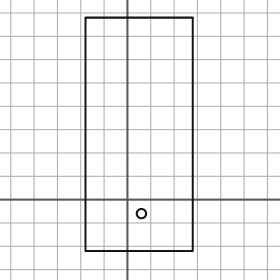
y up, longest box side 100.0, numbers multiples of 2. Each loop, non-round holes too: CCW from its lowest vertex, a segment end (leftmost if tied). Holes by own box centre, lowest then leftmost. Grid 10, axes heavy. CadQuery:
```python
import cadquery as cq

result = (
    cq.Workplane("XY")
    .moveTo(-18.0, -22.0)
    .lineTo(28.0, -22.0)
    .lineTo(28.0, 78.0)
    .lineTo(-18.0, 78.0)
    .close()
    .moveTo(6.0, -6.0)
    .circle(2.0)
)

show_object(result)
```